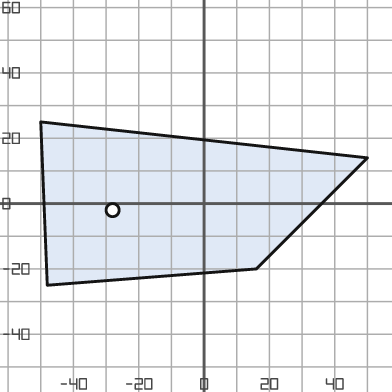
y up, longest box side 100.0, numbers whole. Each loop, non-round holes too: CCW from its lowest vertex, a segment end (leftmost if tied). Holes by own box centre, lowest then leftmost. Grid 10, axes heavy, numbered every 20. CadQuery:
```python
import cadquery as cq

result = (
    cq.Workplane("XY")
    .moveTo(-48.0, -25.0)
    .lineTo(16.0, -20.0)
    .lineTo(50.0, 14.0)
    .lineTo(-50.0, 25.0)
    .close()
    .moveTo(-28.0, -2.0)
    .circle(2.0)
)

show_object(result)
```